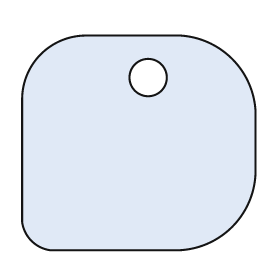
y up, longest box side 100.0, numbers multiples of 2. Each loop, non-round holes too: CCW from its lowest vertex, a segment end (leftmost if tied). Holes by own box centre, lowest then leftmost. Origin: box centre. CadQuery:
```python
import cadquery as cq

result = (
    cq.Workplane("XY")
    .moveTo(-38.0, -46.0)
    .lineTo(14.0, -46.0)
    .threePointArc((40.0, -36.0), (50.0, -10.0))
    .lineTo(50.0, 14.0)
    .threePointArc((40.0, 36.0), (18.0, 46.0))
    .lineTo(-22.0, 46.0)
    .threePointArc((-42.0, 38.0), (-50.0, 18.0))
    .lineTo(-50.0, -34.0)
    .threePointArc((-46.0, -42.0), (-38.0, -46.0))
    .close()
    .moveTo(4.0, 28.0)
    .circle(8.0)
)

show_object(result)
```